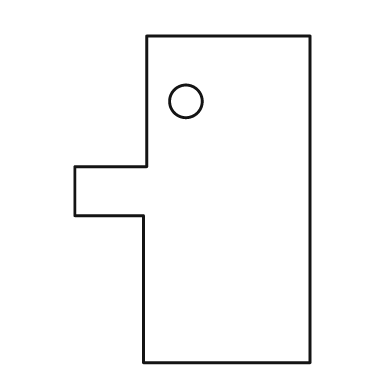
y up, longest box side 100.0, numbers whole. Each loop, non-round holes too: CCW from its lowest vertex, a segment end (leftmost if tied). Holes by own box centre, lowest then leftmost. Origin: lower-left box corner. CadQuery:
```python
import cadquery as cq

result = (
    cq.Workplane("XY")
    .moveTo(21.0, 0.0)
    .lineTo(72.0, 0.0)
    .lineTo(72.0, 100.0)
    .lineTo(22.0, 100.0)
    .lineTo(22.0, 60.0)
    .lineTo(0.0, 60.0)
    .lineTo(0.0, 45.0)
    .lineTo(21.0, 45.0)
    .close()
    .moveTo(34.0, 80.0)
    .circle(5.0)
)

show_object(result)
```